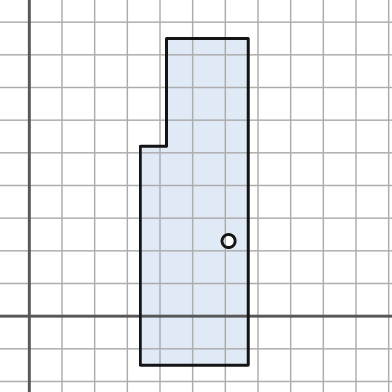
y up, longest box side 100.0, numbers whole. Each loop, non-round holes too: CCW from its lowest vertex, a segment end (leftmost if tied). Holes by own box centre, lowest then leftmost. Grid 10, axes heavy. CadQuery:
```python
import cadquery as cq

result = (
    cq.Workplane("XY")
    .moveTo(34.0, -15.0)
    .lineTo(67.0, -15.0)
    .lineTo(67.0, 85.0)
    .lineTo(42.0, 85.0)
    .lineTo(42.0, 52.0)
    .lineTo(34.0, 52.0)
    .close()
    .moveTo(61.0, 23.0)
    .circle(2.0)
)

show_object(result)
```